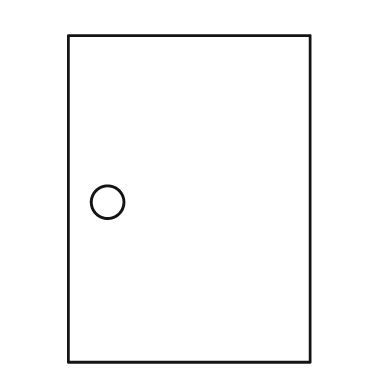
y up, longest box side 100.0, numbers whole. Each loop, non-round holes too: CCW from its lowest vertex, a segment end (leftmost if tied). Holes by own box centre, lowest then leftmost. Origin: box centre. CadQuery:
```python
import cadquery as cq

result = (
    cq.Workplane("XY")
    .moveTo(-37.0, -50.0)
    .lineTo(37.0, -50.0)
    .lineTo(37.0, 50.0)
    .lineTo(-37.0, 50.0)
    .close()
    .moveTo(-25.0, -1.0)
    .circle(5.0)
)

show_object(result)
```